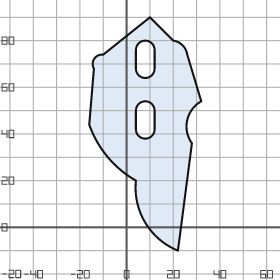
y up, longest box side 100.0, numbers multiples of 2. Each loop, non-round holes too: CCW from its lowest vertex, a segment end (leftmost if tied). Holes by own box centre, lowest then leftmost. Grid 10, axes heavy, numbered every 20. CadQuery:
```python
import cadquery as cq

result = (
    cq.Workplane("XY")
    .moveTo(22.0, -10.0)
    .lineTo(28.0, 36.0)
    .threePointArc((26.0, 46.0), (32.0, 54.0))
    .lineTo(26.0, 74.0)
    .threePointArc((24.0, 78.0), (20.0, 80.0))
    .lineTo(10.0, 90.0)
    .lineTo(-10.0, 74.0)
    .threePointArc((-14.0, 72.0), (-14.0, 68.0))
    .lineTo(-16.0, 44.0)
    .threePointArc((-8.0, 30.0), (4.0, 20.0))
    .threePointArc((8.0, 2.0), (22.0, -10.0))
    .close()
    .moveTo(4.0, 42.0)
    .threePointArc((8.0, 38.0), (12.0, 42.0))
    .lineTo(12.0, 50.0)
    .threePointArc((8.0, 54.0), (4.0, 50.0))
    .close()
    .moveTo(4.0, 68.0)
    .threePointArc((8.0, 64.0), (12.0, 68.0))
    .lineTo(12.0, 76.0)
    .threePointArc((8.0, 80.0), (4.0, 76.0))
    .close()
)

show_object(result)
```